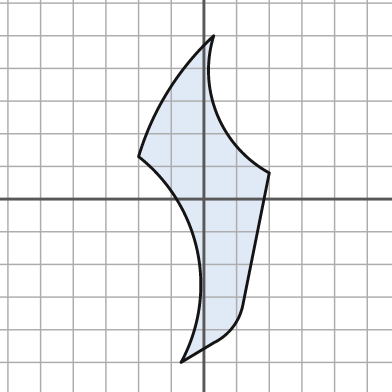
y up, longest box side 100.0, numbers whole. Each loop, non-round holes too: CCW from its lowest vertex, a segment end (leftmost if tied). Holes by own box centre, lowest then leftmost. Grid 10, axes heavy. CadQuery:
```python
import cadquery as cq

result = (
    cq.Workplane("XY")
    .moveTo(-7.0, -50.0)
    .lineTo(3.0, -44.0)
    .threePointArc((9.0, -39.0), (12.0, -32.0))
    .lineTo(20.0, 8.0)
    .threePointArc((4.0, 26.0), (3.0, 50.0))
    .threePointArc((-11.0, 33.0), (-20.0, 13.0))
    .threePointArc((-2.0, -16.0), (-7.0, -50.0))
    .close()
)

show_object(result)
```